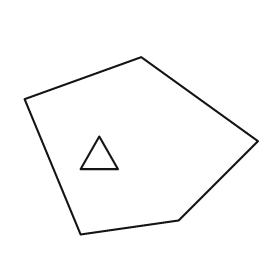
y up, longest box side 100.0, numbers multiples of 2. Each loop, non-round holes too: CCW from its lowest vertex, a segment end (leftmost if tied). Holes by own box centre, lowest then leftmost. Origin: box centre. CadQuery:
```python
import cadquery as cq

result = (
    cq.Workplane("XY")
    .moveTo(-26.0, -38.0)
    .lineTo(16.0, -32.0)
    .lineTo(50.0, 2.0)
    .lineTo(0.0, 38.0)
    .lineTo(-50.0, 20.0)
    .close()
    .moveTo(-26.0, -10.0)
    .lineTo(-10.0, -10.0)
    .lineTo(-18.0, 4.0)
    .close()
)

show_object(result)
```